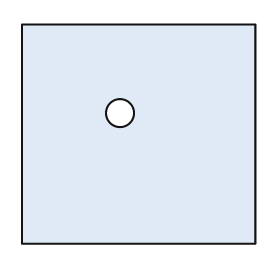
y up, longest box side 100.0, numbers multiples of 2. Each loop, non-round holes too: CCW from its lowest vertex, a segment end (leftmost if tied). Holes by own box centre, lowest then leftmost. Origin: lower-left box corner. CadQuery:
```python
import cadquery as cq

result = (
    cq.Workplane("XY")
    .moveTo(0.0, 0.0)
    .lineTo(100.0, 0.0)
    .lineTo(100.0, 94.0)
    .lineTo(0.0, 94.0)
    .close()
    .moveTo(42.0, 56.0)
    .circle(6.0)
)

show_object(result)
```